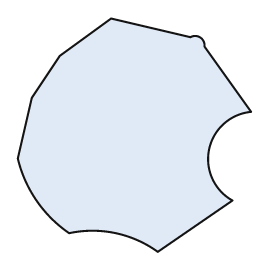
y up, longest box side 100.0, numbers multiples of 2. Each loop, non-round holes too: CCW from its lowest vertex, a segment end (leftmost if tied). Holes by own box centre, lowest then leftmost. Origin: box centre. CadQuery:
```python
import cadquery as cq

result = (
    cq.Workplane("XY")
    .moveTo(10.0, -50.0)
    .lineTo(42.0, -28.0)
    .threePointArc((32.0, -6.0), (50.0, 10.0))
    .lineTo(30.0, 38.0)
    .threePointArc((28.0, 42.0), (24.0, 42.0))
    .lineTo(-10.0, 50.0)
    .lineTo(-32.0, 34.0)
    .lineTo(-44.0, 16.0)
    .lineTo(-50.0, -10.0)
    .threePointArc((-42.0, -28.0), (-28.0, -42.0))
    .threePointArc((-8.0, -42.0), (10.0, -50.0))
    .close()
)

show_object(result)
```